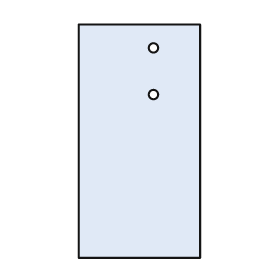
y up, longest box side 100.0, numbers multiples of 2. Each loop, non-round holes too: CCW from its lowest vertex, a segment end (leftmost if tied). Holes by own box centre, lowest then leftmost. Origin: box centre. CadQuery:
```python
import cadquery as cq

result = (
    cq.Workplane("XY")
    .moveTo(-26.0, -50.0)
    .lineTo(26.0, -50.0)
    .lineTo(26.0, 50.0)
    .lineTo(-26.0, 50.0)
    .close()
    .moveTo(6.0, 20.0)
    .circle(2.0)
    .moveTo(6.0, 40.0)
    .circle(2.0)
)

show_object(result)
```